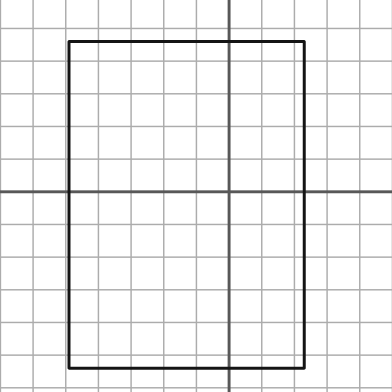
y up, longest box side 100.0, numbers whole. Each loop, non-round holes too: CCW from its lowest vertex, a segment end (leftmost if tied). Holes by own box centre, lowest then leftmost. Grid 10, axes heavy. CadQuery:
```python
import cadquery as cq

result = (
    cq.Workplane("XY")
    .moveTo(-49.0, -54.0)
    .lineTo(23.0, -54.0)
    .lineTo(23.0, 46.0)
    .lineTo(-49.0, 46.0)
    .close()
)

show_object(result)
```